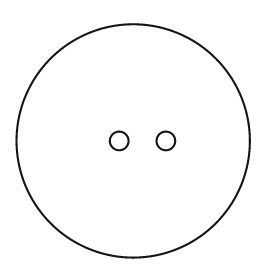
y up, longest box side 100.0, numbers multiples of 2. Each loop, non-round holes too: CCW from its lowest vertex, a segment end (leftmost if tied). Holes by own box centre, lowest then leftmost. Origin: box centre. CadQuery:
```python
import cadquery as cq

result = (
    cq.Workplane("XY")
    .moveTo(0.0, 0.0)
    .circle(50.0)
    .moveTo(-6.0, 0.0)
    .circle(4.0)
    .moveTo(14.0, 0.0)
    .circle(4.0)
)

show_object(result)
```